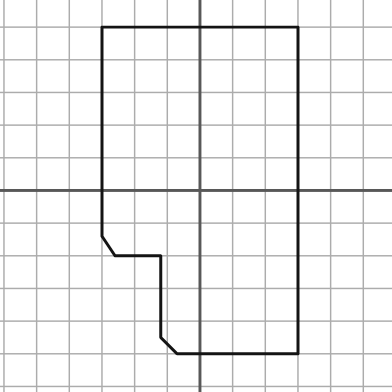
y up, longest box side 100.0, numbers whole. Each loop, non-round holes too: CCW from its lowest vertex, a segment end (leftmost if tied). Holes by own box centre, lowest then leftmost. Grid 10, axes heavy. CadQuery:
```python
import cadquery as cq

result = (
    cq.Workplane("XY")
    .moveTo(-7.0, -50.0)
    .lineTo(30.0, -50.0)
    .lineTo(30.0, 50.0)
    .lineTo(-30.0, 50.0)
    .lineTo(-30.0, -14.0)
    .lineTo(-26.0, -20.0)
    .lineTo(-12.0, -20.0)
    .lineTo(-12.0, -45.0)
    .close()
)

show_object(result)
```